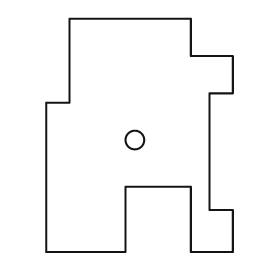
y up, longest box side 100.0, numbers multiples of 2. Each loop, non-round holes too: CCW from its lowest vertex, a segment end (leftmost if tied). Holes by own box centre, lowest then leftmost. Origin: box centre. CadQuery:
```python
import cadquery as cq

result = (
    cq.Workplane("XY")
    .moveTo(-40.0, -50.0)
    .lineTo(-6.0, -50.0)
    .lineTo(-6.0, -22.0)
    .lineTo(22.0, -22.0)
    .lineTo(22.0, -50.0)
    .lineTo(40.0, -50.0)
    .lineTo(40.0, -32.0)
    .lineTo(30.0, -32.0)
    .lineTo(30.0, 18.0)
    .lineTo(40.0, 18.0)
    .lineTo(40.0, 34.0)
    .lineTo(22.0, 34.0)
    .lineTo(22.0, 50.0)
    .lineTo(-30.0, 50.0)
    .lineTo(-30.0, 14.0)
    .lineTo(-40.0, 14.0)
    .close()
    .moveTo(-2.0, -2.0)
    .circle(4.0)
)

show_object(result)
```